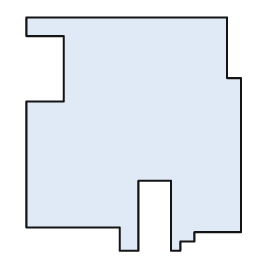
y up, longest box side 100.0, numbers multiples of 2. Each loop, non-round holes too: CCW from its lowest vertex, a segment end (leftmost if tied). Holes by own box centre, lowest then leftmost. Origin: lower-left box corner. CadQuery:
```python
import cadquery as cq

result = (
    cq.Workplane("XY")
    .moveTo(40.0, 0.0)
    .lineTo(48.0, 0.0)
    .lineTo(48.0, 30.0)
    .lineTo(62.0, 30.0)
    .lineTo(62.0, 0.0)
    .lineTo(66.0, 0.0)
    .lineTo(66.0, 4.0)
    .lineTo(72.0, 4.0)
    .lineTo(72.0, 8.0)
    .lineTo(92.0, 8.0)
    .lineTo(92.0, 74.0)
    .lineTo(86.0, 74.0)
    .lineTo(86.0, 100.0)
    .lineTo(0.0, 100.0)
    .lineTo(0.0, 92.0)
    .lineTo(16.0, 92.0)
    .lineTo(16.0, 64.0)
    .lineTo(0.0, 64.0)
    .lineTo(0.0, 10.0)
    .lineTo(40.0, 10.0)
    .close()
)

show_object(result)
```